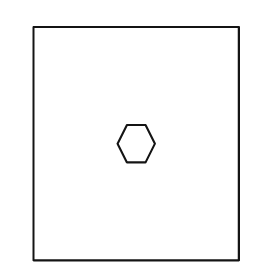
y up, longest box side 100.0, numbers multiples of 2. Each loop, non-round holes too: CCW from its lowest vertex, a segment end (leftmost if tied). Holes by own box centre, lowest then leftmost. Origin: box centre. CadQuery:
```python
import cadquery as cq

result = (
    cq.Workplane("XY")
    .moveTo(-44.0, -50.0)
    .lineTo(44.0, -50.0)
    .lineTo(44.0, 50.0)
    .lineTo(-44.0, 50.0)
    .close()
    .moveTo(-4.0, -8.0)
    .lineTo(4.0, -8.0)
    .lineTo(8.0, 0.0)
    .lineTo(4.0, 8.0)
    .lineTo(-4.0, 8.0)
    .lineTo(-8.0, 0.0)
    .close()
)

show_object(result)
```